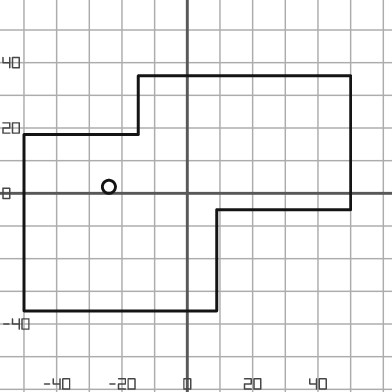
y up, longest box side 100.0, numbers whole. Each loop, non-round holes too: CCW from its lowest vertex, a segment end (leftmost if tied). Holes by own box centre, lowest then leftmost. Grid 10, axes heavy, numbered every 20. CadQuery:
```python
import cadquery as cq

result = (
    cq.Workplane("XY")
    .moveTo(-50.0, -36.0)
    .lineTo(9.0, -36.0)
    .lineTo(9.0, -5.0)
    .lineTo(50.0, -5.0)
    .lineTo(50.0, 36.0)
    .lineTo(-15.0, 36.0)
    .lineTo(-15.0, 18.0)
    .lineTo(-50.0, 18.0)
    .close()
    .moveTo(-24.0, 2.0)
    .circle(2.0)
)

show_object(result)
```